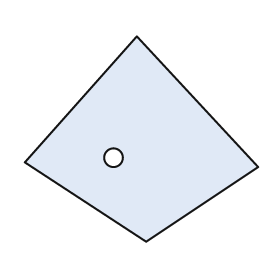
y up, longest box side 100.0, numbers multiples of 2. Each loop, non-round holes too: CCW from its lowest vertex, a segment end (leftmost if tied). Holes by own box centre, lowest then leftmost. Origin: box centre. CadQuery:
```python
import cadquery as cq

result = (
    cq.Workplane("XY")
    .moveTo(2.0, -44.0)
    .lineTo(50.0, -12.0)
    .lineTo(-2.0, 44.0)
    .lineTo(-50.0, -10.0)
    .close()
    .moveTo(-12.0, -8.0)
    .circle(4.0)
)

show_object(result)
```